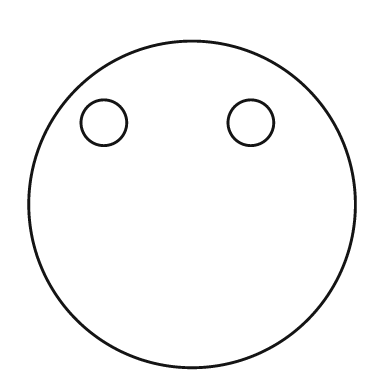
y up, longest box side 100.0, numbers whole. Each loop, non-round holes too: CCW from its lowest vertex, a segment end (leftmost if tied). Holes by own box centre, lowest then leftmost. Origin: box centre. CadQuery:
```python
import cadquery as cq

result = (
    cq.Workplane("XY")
    .moveTo(0.0, 0.0)
    .circle(50.0)
    .moveTo(-27.0, 25.0)
    .circle(7.0)
    .moveTo(18.0, 25.0)
    .circle(7.0)
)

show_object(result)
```